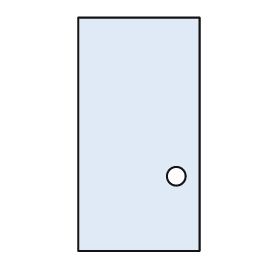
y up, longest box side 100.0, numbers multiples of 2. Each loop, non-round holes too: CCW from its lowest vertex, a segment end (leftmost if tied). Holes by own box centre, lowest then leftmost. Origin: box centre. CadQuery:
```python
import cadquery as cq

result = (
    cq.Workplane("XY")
    .moveTo(-26.0, -50.0)
    .lineTo(26.0, -50.0)
    .lineTo(26.0, 50.0)
    .lineTo(-26.0, 50.0)
    .close()
    .moveTo(16.0, -18.0)
    .circle(4.0)
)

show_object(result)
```